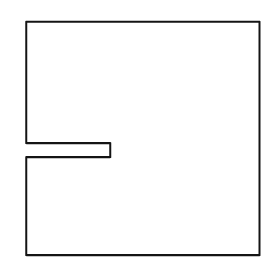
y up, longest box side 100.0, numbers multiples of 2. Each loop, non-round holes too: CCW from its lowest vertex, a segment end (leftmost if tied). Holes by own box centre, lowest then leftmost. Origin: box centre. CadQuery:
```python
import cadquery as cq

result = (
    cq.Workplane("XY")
    .moveTo(-50.0, -50.0)
    .lineTo(50.0, -50.0)
    .lineTo(50.0, 50.0)
    .lineTo(-50.0, 50.0)
    .lineTo(-50.0, -2.0)
    .lineTo(-14.0, -2.0)
    .lineTo(-14.0, -8.0)
    .lineTo(-50.0, -8.0)
    .close()
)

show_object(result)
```